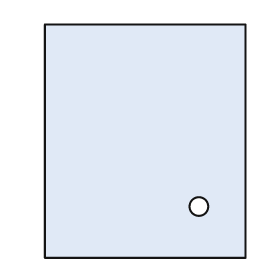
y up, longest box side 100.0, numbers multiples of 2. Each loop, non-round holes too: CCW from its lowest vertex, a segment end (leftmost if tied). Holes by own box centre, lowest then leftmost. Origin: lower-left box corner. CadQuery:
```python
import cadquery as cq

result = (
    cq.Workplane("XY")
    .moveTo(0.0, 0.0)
    .lineTo(86.0, 0.0)
    .lineTo(86.0, 100.0)
    .lineTo(0.0, 100.0)
    .close()
    .moveTo(66.0, 22.0)
    .circle(4.0)
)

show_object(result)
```